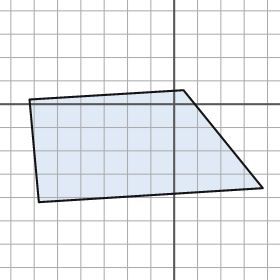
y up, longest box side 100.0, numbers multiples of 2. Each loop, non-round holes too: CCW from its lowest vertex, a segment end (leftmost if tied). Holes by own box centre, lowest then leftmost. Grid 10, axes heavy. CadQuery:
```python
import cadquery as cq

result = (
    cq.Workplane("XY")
    .moveTo(-58.0, -42.0)
    .lineTo(38.0, -36.0)
    .lineTo(4.0, 6.0)
    .lineTo(-62.0, 2.0)
    .close()
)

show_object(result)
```